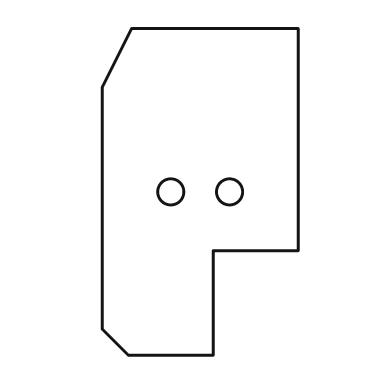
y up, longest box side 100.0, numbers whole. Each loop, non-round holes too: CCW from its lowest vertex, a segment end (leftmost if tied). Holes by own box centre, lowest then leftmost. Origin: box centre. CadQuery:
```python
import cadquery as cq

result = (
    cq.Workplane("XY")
    .moveTo(-22.0, -50.0)
    .lineTo(4.0, -50.0)
    .lineTo(4.0, -18.0)
    .lineTo(30.0, -18.0)
    .lineTo(30.0, 50.0)
    .lineTo(-21.0, 50.0)
    .lineTo(-30.0, 32.0)
    .lineTo(-30.0, -42.0)
    .close()
    .moveTo(-9.0, 0.0)
    .circle(4.0)
    .moveTo(9.0, 0.0)
    .circle(4.0)
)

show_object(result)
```